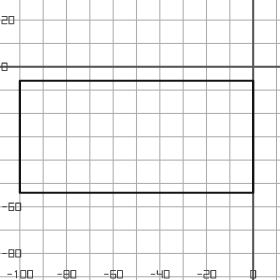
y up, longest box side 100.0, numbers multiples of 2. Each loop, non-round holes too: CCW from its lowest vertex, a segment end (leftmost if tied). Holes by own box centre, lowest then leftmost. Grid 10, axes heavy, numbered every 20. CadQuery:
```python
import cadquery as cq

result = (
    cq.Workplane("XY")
    .moveTo(-100.0, -54.0)
    .lineTo(0.0, -54.0)
    .lineTo(0.0, -6.0)
    .lineTo(-100.0, -6.0)
    .close()
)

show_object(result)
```